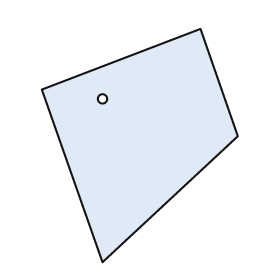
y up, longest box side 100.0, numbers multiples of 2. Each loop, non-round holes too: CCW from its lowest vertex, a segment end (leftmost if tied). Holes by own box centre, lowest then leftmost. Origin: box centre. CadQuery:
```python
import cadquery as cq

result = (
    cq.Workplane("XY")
    .moveTo(-16.0, -50.0)
    .lineTo(42.0, 4.0)
    .lineTo(26.0, 50.0)
    .lineTo(-42.0, 24.0)
    .close()
    .moveTo(-16.0, 20.0)
    .circle(2.0)
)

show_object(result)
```